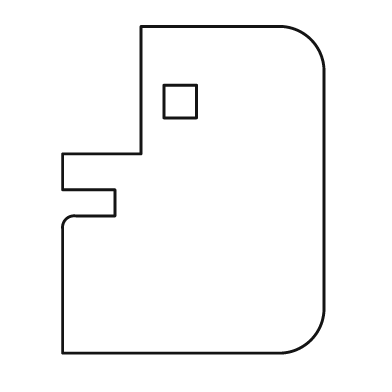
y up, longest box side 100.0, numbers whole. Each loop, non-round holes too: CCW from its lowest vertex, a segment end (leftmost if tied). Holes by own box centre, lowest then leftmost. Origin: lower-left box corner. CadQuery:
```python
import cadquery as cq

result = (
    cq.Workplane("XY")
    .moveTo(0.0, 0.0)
    .lineTo(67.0, 0.0)
    .threePointArc((76.0, 4.0), (80.0, 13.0))
    .lineTo(80.0, 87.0)
    .threePointArc((76.0, 96.0), (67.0, 100.0))
    .lineTo(24.0, 100.0)
    .lineTo(24.0, 61.0)
    .lineTo(0.0, 61.0)
    .lineTo(0.0, 50.0)
    .lineTo(16.0, 50.0)
    .lineTo(16.0, 42.0)
    .lineTo(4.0, 42.0)
    .threePointArc((1.0, 41.0), (0.0, 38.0))
    .close()
    .moveTo(31.0, 72.0)
    .lineTo(41.0, 72.0)
    .lineTo(41.0, 82.0)
    .lineTo(31.0, 82.0)
    .close()
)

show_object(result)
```